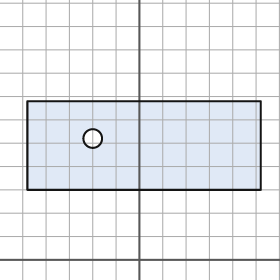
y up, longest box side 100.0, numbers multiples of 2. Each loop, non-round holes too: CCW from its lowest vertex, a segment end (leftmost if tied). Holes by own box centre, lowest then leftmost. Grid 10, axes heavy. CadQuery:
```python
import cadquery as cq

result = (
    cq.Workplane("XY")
    .moveTo(-48.0, 30.0)
    .lineTo(52.0, 30.0)
    .lineTo(52.0, 68.0)
    .lineTo(-48.0, 68.0)
    .close()
    .moveTo(-20.0, 52.0)
    .circle(4.0)
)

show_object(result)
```